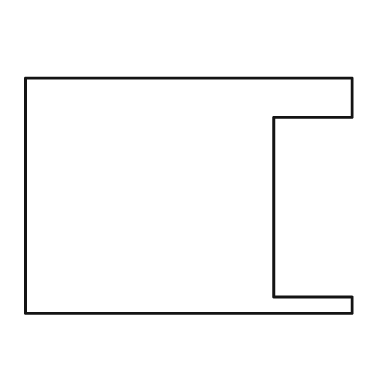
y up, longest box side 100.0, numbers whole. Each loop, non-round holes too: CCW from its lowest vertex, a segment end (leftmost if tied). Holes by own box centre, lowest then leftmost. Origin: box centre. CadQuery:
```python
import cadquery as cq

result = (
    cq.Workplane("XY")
    .moveTo(-50.0, -36.0)
    .lineTo(50.0, -36.0)
    .lineTo(50.0, -31.0)
    .lineTo(26.0, -31.0)
    .lineTo(26.0, 24.0)
    .lineTo(50.0, 24.0)
    .lineTo(50.0, 36.0)
    .lineTo(-50.0, 36.0)
    .close()
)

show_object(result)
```